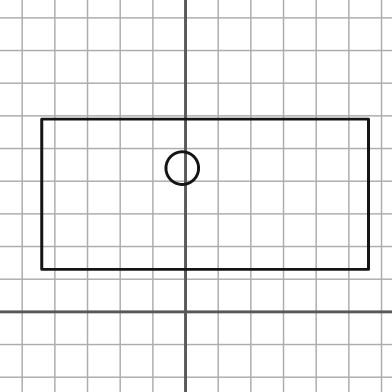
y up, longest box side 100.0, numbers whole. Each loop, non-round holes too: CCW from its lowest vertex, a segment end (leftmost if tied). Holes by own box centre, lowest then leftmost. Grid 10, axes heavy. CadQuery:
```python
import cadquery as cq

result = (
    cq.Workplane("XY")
    .moveTo(-44.0, 13.0)
    .lineTo(56.0, 13.0)
    .lineTo(56.0, 59.0)
    .lineTo(-44.0, 59.0)
    .close()
    .moveTo(-1.0, 44.0)
    .circle(5.0)
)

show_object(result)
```